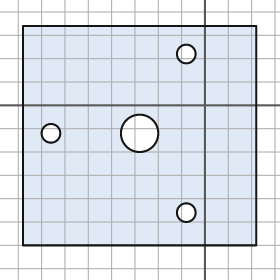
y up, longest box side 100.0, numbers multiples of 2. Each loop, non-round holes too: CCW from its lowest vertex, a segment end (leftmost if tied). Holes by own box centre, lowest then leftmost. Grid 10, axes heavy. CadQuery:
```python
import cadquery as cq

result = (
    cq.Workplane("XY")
    .moveTo(-78.0, -60.0)
    .lineTo(22.0, -60.0)
    .lineTo(22.0, 34.0)
    .lineTo(-78.0, 34.0)
    .close()
    .moveTo(-8.0, -46.0)
    .circle(4.0)
    .moveTo(-66.0, -12.0)
    .circle(4.0)
    .moveTo(-28.0, -12.0)
    .circle(8.0)
    .moveTo(-8.0, 22.0)
    .circle(4.0)
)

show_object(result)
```